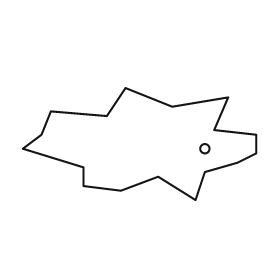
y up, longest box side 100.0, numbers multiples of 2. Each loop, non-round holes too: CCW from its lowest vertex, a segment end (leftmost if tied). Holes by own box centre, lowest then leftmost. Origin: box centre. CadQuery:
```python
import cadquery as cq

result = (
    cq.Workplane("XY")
    .moveTo(24.0, -24.0)
    .lineTo(28.0, -12.0)
    .lineTo(42.0, -8.0)
    .lineTo(50.0, -4.0)
    .lineTo(50.0, 4.0)
    .lineTo(32.0, 6.0)
    .lineTo(38.0, 20.0)
    .lineTo(14.0, 16.0)
    .lineTo(-6.0, 24.0)
    .lineTo(-14.0, 12.0)
    .lineTo(-38.0, 14.0)
    .lineTo(-42.0, 4.0)
    .lineTo(-50.0, -2.0)
    .lineTo(-24.0, -10.0)
    .lineTo(-24.0, -18.0)
    .lineTo(-8.0, -20.0)
    .lineTo(8.0, -14.0)
    .close()
    .moveTo(28.0, -2.0)
    .circle(2.0)
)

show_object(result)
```